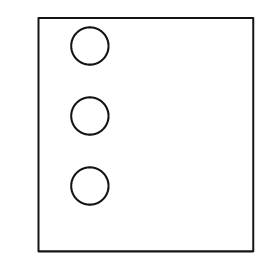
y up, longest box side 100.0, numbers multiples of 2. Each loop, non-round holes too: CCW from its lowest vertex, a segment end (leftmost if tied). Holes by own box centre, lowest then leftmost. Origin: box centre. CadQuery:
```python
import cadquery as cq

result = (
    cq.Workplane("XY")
    .moveTo(-46.0, -50.0)
    .lineTo(46.0, -50.0)
    .lineTo(46.0, 50.0)
    .lineTo(-46.0, 50.0)
    .close()
    .moveTo(-24.0, -22.0)
    .circle(8.0)
    .moveTo(-24.0, 8.0)
    .circle(8.0)
    .moveTo(-24.0, 38.0)
    .circle(8.0)
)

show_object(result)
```